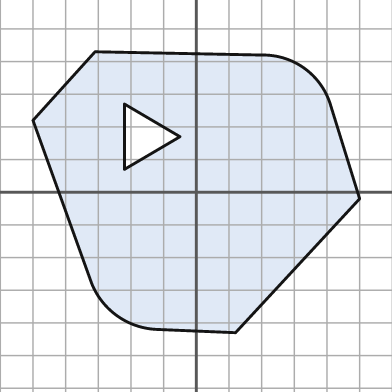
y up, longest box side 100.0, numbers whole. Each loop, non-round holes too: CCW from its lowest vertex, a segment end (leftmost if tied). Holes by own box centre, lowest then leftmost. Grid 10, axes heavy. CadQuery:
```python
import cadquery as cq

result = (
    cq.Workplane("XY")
    .moveTo(12.0, -43.0)
    .lineTo(50.0, -2.0)
    .lineTo(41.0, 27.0)
    .threePointArc((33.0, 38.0), (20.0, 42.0))
    .lineTo(-31.0, 43.0)
    .lineTo(-50.0, 22.0)
    .lineTo(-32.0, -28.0)
    .threePointArc((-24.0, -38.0), (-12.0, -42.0))
    .close()
    .moveTo(-22.0, 7.0)
    .lineTo(-5.0, 17.0)
    .lineTo(-22.0, 27.0)
    .close()
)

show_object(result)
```